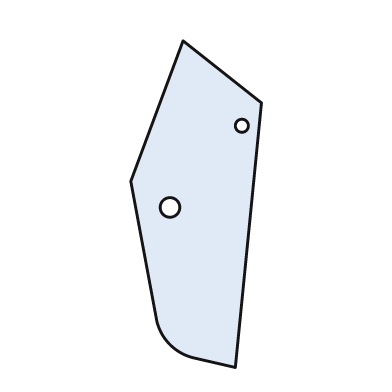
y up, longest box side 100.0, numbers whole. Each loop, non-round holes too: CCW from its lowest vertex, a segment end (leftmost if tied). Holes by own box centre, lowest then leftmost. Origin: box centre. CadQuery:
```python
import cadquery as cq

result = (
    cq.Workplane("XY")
    .moveTo(12.0, -50.0)
    .lineTo(20.0, 31.0)
    .lineTo(-4.0, 50.0)
    .lineTo(-20.0, 7.0)
    .lineTo(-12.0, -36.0)
    .threePointArc((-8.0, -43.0), (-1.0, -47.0))
    .close()
    .moveTo(-8.0, -1.0)
    .circle(3.0)
    .moveTo(14.0, 24.0)
    .circle(2.0)
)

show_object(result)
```